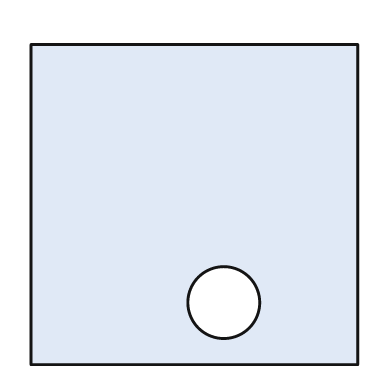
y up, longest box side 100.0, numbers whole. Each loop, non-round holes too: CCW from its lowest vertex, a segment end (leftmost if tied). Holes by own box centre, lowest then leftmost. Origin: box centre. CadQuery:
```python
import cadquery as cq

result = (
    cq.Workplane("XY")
    .moveTo(-50.0, -49.0)
    .lineTo(50.0, -49.0)
    .lineTo(50.0, 49.0)
    .lineTo(-50.0, 49.0)
    .close()
    .moveTo(9.0, -30.0)
    .circle(11.0)
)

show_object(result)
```